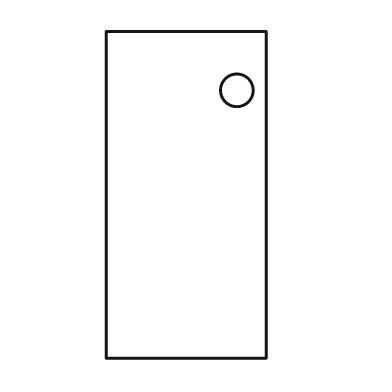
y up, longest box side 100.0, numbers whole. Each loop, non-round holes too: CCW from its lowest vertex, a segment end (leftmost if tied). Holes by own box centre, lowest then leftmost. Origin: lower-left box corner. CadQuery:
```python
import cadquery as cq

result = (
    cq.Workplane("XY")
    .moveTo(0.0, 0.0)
    .lineTo(49.0, 0.0)
    .lineTo(49.0, 100.0)
    .lineTo(0.0, 100.0)
    .close()
    .moveTo(40.0, 82.0)
    .circle(5.0)
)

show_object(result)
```